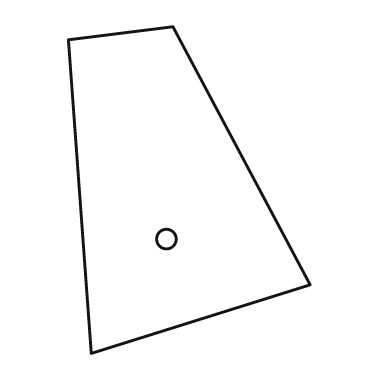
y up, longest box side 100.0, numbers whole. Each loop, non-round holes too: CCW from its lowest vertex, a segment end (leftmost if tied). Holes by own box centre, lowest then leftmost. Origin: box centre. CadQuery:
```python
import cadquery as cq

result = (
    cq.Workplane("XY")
    .moveTo(-30.0, -50.0)
    .lineTo(37.0, -29.0)
    .lineTo(-5.0, 50.0)
    .lineTo(-37.0, 46.0)
    .close()
    .moveTo(-7.0, -15.0)
    .circle(3.0)
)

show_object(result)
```